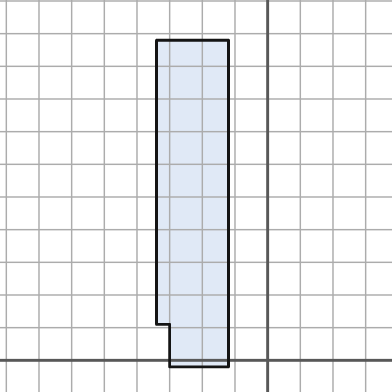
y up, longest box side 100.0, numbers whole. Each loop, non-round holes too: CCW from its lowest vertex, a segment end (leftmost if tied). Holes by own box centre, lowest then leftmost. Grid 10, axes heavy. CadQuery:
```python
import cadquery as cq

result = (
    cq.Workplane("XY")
    .moveTo(-30.0, -2.0)
    .lineTo(-12.0, -2.0)
    .lineTo(-12.0, 98.0)
    .lineTo(-34.0, 98.0)
    .lineTo(-34.0, 11.0)
    .lineTo(-30.0, 11.0)
    .close()
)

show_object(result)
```